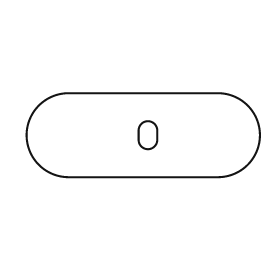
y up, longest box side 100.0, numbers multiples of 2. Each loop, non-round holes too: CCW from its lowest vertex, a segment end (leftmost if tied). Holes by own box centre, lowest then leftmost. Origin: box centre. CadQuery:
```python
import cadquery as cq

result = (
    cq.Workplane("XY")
    .moveTo(-32.0, -18.0)
    .lineTo(32.0, -18.0)
    .threePointArc((50.0, 0.0), (32.0, 18.0))
    .lineTo(-32.0, 18.0)
    .threePointArc((-50.0, 0.0), (-32.0, -18.0))
    .close()
    .moveTo(-2.0, -2.0)
    .threePointArc((2.0, -6.0), (6.0, -2.0))
    .lineTo(6.0, 2.0)
    .threePointArc((2.0, 6.0), (-2.0, 2.0))
    .close()
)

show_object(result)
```